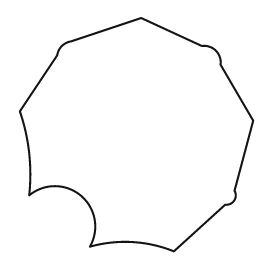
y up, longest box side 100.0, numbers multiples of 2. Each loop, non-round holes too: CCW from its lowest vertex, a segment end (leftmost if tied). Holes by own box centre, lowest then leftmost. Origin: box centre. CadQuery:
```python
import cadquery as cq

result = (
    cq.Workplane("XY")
    .moveTo(16.0, -50.0)
    .lineTo(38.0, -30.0)
    .threePointArc((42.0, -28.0), (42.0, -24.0))
    .lineTo(50.0, 6.0)
    .lineTo(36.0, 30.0)
    .threePointArc((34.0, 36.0), (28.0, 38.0))
    .lineTo(2.0, 50.0)
    .lineTo(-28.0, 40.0)
    .threePointArc((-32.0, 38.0), (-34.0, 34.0))
    .lineTo(-50.0, 10.0)
    .threePointArc((-46.0, -8.0), (-46.0, -26.0))
    .threePointArc((-24.0, -26.0), (-20.0, -48.0))
    .threePointArc((-2.0, -46.0), (16.0, -50.0))
    .close()
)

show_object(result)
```